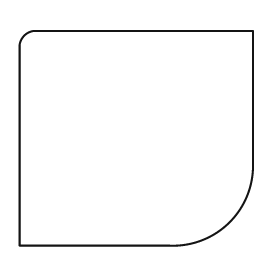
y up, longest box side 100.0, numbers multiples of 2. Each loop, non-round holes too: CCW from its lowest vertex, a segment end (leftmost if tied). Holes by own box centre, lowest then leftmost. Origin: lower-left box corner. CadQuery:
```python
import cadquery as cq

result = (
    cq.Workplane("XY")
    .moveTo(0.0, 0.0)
    .lineTo(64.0, 0.0)
    .threePointArc((90.0, 10.0), (100.0, 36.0))
    .lineTo(100.0, 92.0)
    .lineTo(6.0, 92.0)
    .threePointArc((2.0, 90.0), (0.0, 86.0))
    .close()
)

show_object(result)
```